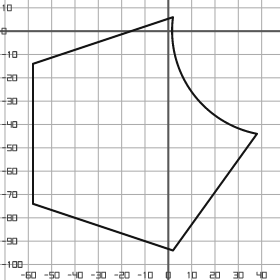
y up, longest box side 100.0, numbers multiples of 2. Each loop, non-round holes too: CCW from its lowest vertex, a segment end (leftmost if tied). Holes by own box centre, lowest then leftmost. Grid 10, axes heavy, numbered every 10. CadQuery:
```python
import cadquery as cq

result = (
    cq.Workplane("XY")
    .moveTo(2.0, -94.0)
    .lineTo(38.0, -44.0)
    .threePointArc((10.0, -26.0), (2.0, 6.0))
    .lineTo(-58.0, -14.0)
    .lineTo(-58.0, -74.0)
    .close()
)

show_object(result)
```